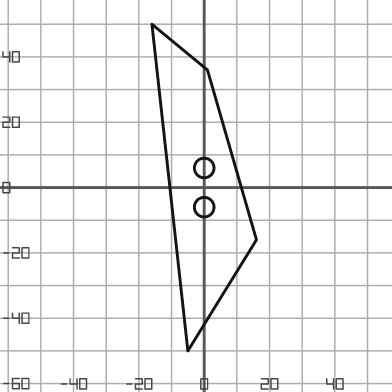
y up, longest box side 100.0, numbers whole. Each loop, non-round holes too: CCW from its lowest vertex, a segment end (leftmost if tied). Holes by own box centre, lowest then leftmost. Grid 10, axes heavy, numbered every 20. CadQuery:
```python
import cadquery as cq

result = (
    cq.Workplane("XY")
    .moveTo(-5.0, -50.0)
    .lineTo(16.0, -16.0)
    .lineTo(1.0, 36.0)
    .lineTo(-16.0, 50.0)
    .close()
    .moveTo(0.0, -6.0)
    .circle(3.0)
    .moveTo(0.0, 6.0)
    .circle(3.0)
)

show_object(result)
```